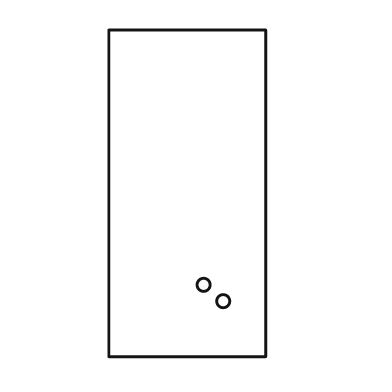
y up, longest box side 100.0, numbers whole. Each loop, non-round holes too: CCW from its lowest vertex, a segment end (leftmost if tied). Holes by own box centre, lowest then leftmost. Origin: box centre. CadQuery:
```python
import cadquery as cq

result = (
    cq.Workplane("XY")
    .moveTo(-24.0, -50.0)
    .lineTo(24.0, -50.0)
    .lineTo(24.0, 50.0)
    .lineTo(-24.0, 50.0)
    .close()
    .moveTo(11.0, -33.0)
    .circle(2.0)
    .moveTo(5.0, -28.0)
    .circle(2.0)
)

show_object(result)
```